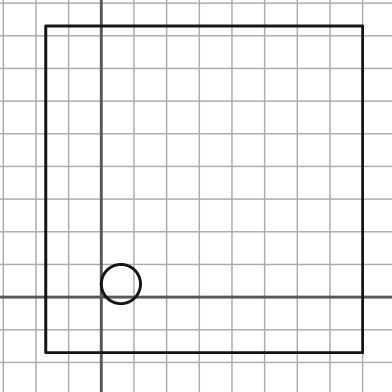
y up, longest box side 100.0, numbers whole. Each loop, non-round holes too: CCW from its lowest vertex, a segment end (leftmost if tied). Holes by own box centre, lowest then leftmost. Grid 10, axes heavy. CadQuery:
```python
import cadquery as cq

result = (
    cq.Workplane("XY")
    .moveTo(-17.0, -17.0)
    .lineTo(80.0, -17.0)
    .lineTo(80.0, 83.0)
    .lineTo(-17.0, 83.0)
    .close()
    .moveTo(6.0, 4.0)
    .circle(6.0)
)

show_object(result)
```